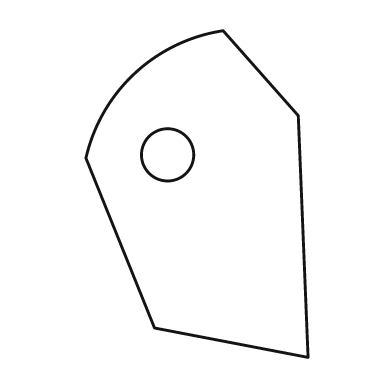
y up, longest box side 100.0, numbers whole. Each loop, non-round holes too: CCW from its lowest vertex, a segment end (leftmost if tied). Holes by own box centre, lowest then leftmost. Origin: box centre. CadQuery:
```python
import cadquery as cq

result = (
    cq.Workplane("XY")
    .moveTo(34.0, -50.0)
    .lineTo(31.0, 24.0)
    .lineTo(8.0, 50.0)
    .threePointArc((-19.0, 37.0), (-34.0, 11.0))
    .lineTo(-13.0, -41.0)
    .close()
    .moveTo(-9.0, 12.0)
    .circle(8.0)
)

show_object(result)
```